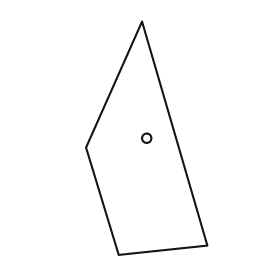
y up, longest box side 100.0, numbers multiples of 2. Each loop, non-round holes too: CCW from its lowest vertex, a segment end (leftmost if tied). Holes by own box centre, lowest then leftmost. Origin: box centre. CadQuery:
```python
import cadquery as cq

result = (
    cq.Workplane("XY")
    .moveTo(-12.0, -50.0)
    .lineTo(26.0, -46.0)
    .lineTo(-2.0, 50.0)
    .lineTo(-26.0, -4.0)
    .close()
    .moveTo(0.0, 0.0)
    .circle(2.0)
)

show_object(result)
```